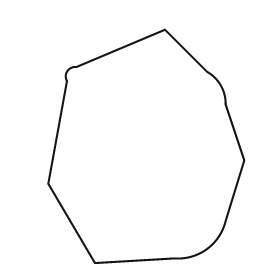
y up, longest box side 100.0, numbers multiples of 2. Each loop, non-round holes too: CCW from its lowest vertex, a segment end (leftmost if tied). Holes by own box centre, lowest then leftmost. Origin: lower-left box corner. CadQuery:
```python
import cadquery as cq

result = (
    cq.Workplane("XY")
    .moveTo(20.0, 0.0)
    .lineTo(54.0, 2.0)
    .threePointArc((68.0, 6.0), (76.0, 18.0))
    .lineTo(84.0, 44.0)
    .lineTo(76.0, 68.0)
    .threePointArc((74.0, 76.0), (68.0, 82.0))
    .lineTo(50.0, 100.0)
    .lineTo(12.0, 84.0)
    .threePointArc((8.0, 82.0), (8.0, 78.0))
    .lineTo(0.0, 34.0)
    .close()
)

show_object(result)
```